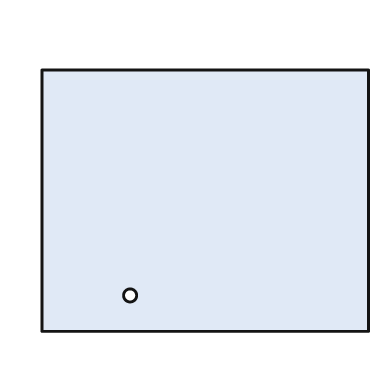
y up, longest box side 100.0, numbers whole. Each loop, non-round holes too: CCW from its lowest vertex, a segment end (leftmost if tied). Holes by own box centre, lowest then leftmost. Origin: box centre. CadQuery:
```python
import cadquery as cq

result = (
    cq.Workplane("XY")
    .moveTo(-50.0, -40.0)
    .lineTo(50.0, -40.0)
    .lineTo(50.0, 40.0)
    .lineTo(-50.0, 40.0)
    .close()
    .moveTo(-23.0, -29.0)
    .circle(2.0)
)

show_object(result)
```